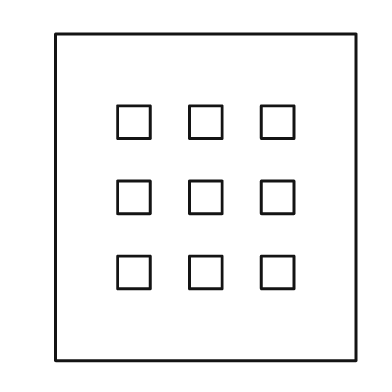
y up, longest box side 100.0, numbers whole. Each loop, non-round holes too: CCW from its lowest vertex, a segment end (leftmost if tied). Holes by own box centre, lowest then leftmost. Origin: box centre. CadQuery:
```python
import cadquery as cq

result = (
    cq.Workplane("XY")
    .moveTo(-46.0, -50.0)
    .lineTo(46.0, -50.0)
    .lineTo(46.0, 50.0)
    .lineTo(-46.0, 50.0)
    .close()
    .moveTo(-27.0, -28.0)
    .lineTo(-17.0, -28.0)
    .lineTo(-17.0, -18.0)
    .lineTo(-27.0, -18.0)
    .close()
    .moveTo(-5.0, -28.0)
    .lineTo(5.0, -28.0)
    .lineTo(5.0, -18.0)
    .lineTo(-5.0, -18.0)
    .close()
    .moveTo(17.0, -28.0)
    .lineTo(27.0, -28.0)
    .lineTo(27.0, -18.0)
    .lineTo(17.0, -18.0)
    .close()
    .moveTo(-27.0, -5.0)
    .lineTo(-17.0, -5.0)
    .lineTo(-17.0, 5.0)
    .lineTo(-27.0, 5.0)
    .close()
    .moveTo(-5.0, -5.0)
    .lineTo(5.0, -5.0)
    .lineTo(5.0, 5.0)
    .lineTo(-5.0, 5.0)
    .close()
    .moveTo(17.0, -5.0)
    .lineTo(27.0, -5.0)
    .lineTo(27.0, 5.0)
    .lineTo(17.0, 5.0)
    .close()
    .moveTo(-27.0, 18.0)
    .lineTo(-17.0, 18.0)
    .lineTo(-17.0, 28.0)
    .lineTo(-27.0, 28.0)
    .close()
    .moveTo(-5.0, 18.0)
    .lineTo(5.0, 18.0)
    .lineTo(5.0, 28.0)
    .lineTo(-5.0, 28.0)
    .close()
    .moveTo(17.0, 18.0)
    .lineTo(27.0, 18.0)
    .lineTo(27.0, 28.0)
    .lineTo(17.0, 28.0)
    .close()
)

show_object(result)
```